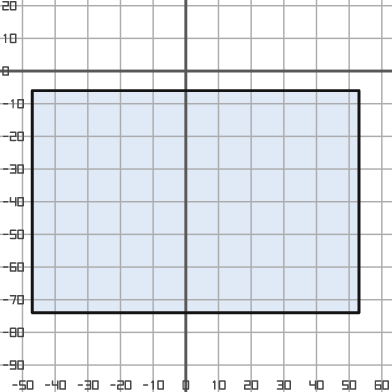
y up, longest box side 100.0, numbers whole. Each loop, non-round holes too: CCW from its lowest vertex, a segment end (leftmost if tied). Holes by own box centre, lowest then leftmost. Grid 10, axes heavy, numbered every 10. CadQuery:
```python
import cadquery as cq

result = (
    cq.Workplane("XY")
    .moveTo(-47.0, -74.0)
    .lineTo(53.0, -74.0)
    .lineTo(53.0, -6.0)
    .lineTo(-47.0, -6.0)
    .close()
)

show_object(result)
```